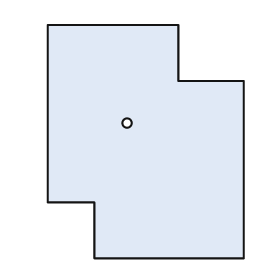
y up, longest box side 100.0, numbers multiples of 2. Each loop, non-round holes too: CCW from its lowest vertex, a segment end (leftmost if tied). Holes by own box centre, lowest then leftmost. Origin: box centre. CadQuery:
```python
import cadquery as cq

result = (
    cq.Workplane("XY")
    .moveTo(-22.0, -50.0)
    .lineTo(42.0, -50.0)
    .lineTo(42.0, 26.0)
    .lineTo(14.0, 26.0)
    .lineTo(14.0, 50.0)
    .lineTo(-42.0, 50.0)
    .lineTo(-42.0, -26.0)
    .lineTo(-22.0, -26.0)
    .close()
    .moveTo(-8.0, 8.0)
    .circle(2.0)
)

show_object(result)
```